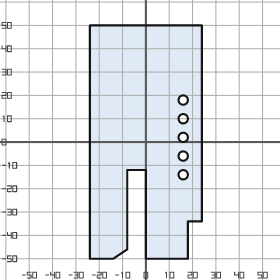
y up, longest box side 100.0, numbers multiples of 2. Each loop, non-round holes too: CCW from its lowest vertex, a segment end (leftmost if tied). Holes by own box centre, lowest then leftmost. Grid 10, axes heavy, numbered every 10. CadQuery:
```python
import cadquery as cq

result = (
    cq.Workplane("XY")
    .moveTo(-24.0, -50.0)
    .lineTo(-14.0, -50.0)
    .lineTo(-8.0, -46.0)
    .lineTo(-8.0, -12.0)
    .lineTo(0.0, -12.0)
    .lineTo(0.0, -50.0)
    .lineTo(18.0, -50.0)
    .lineTo(18.0, -34.0)
    .lineTo(24.0, -34.0)
    .lineTo(24.0, 50.0)
    .lineTo(-24.0, 50.0)
    .close()
    .moveTo(16.0, -14.0)
    .circle(2.0)
    .moveTo(16.0, -6.0)
    .circle(2.0)
    .moveTo(16.0, 2.0)
    .circle(2.0)
    .moveTo(16.0, 10.0)
    .circle(2.0)
    .moveTo(16.0, 18.0)
    .circle(2.0)
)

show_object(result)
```